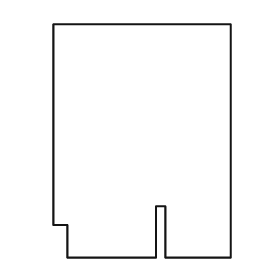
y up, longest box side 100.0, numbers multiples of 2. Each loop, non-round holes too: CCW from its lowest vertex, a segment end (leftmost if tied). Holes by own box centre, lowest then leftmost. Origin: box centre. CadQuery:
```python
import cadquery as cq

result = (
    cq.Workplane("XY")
    .moveTo(-32.0, -50.0)
    .lineTo(6.0, -50.0)
    .lineTo(6.0, -28.0)
    .lineTo(10.0, -28.0)
    .lineTo(10.0, -50.0)
    .lineTo(38.0, -50.0)
    .lineTo(38.0, 50.0)
    .lineTo(-38.0, 50.0)
    .lineTo(-38.0, -36.0)
    .lineTo(-32.0, -36.0)
    .close()
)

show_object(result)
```